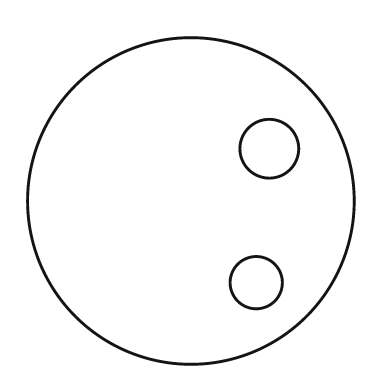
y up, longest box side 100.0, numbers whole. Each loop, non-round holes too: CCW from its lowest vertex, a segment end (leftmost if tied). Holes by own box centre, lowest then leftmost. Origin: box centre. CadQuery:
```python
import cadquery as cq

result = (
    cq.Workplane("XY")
    .moveTo(0.0, 0.0)
    .circle(50.0)
    .moveTo(20.0, -25.0)
    .circle(8.0)
    .moveTo(24.0, 16.0)
    .circle(9.0)
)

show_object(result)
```